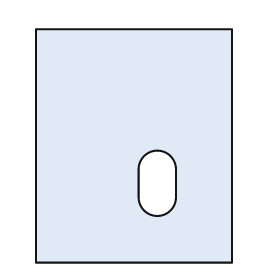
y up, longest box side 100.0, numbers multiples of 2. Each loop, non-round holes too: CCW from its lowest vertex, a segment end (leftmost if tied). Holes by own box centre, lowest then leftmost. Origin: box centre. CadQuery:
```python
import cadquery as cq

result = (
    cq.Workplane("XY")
    .moveTo(-42.0, -50.0)
    .lineTo(42.0, -50.0)
    .lineTo(42.0, 50.0)
    .lineTo(-42.0, 50.0)
    .close()
    .moveTo(2.0, -22.0)
    .threePointArc((10.0, -30.0), (18.0, -22.0))
    .lineTo(18.0, -10.0)
    .threePointArc((10.0, -2.0), (2.0, -10.0))
    .close()
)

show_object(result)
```